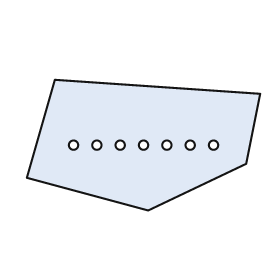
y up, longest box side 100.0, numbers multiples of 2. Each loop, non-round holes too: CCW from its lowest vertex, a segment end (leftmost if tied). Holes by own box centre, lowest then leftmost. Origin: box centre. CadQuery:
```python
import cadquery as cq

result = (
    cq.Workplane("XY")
    .moveTo(2.0, -28.0)
    .lineTo(44.0, -8.0)
    .lineTo(50.0, 22.0)
    .lineTo(-38.0, 28.0)
    .lineTo(-50.0, -14.0)
    .close()
    .moveTo(-30.0, 0.0)
    .circle(2.0)
    .moveTo(-20.0, 0.0)
    .circle(2.0)
    .moveTo(-10.0, 0.0)
    .circle(2.0)
    .moveTo(0.0, 0.0)
    .circle(2.0)
    .moveTo(10.0, 0.0)
    .circle(2.0)
    .moveTo(20.0, 0.0)
    .circle(2.0)
    .moveTo(30.0, 0.0)
    .circle(2.0)
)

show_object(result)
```